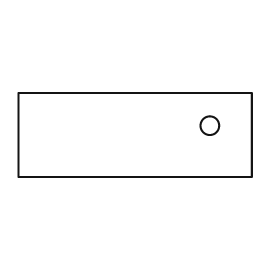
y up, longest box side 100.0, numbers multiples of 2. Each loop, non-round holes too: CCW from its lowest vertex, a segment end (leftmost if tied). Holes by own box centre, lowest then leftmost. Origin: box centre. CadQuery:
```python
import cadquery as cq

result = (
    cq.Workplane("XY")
    .moveTo(-50.0, -18.0)
    .lineTo(50.0, -18.0)
    .lineTo(50.0, 18.0)
    .lineTo(-50.0, 18.0)
    .close()
    .moveTo(32.0, 4.0)
    .circle(4.0)
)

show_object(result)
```